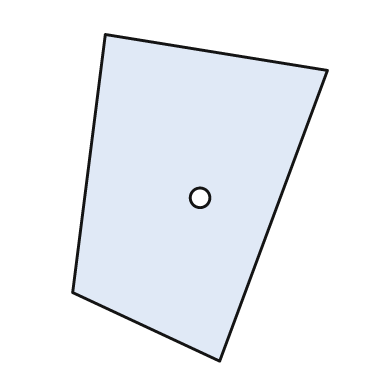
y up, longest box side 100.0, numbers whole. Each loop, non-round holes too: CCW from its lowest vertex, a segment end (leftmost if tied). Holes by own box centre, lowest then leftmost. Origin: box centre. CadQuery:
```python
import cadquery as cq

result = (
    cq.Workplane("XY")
    .moveTo(6.0, -50.0)
    .lineTo(39.0, 39.0)
    .lineTo(-29.0, 50.0)
    .lineTo(-39.0, -29.0)
    .close()
    .moveTo(0.0, 0.0)
    .circle(3.0)
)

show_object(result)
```